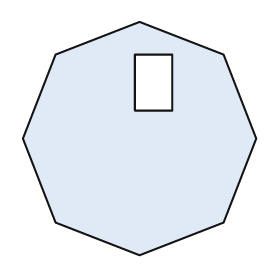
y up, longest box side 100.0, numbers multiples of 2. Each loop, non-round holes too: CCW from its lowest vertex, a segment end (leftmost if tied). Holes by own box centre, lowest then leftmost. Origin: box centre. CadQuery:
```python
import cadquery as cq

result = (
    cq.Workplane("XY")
    .moveTo(0.0, -50.0)
    .lineTo(36.0, -36.0)
    .lineTo(50.0, 0.0)
    .lineTo(36.0, 36.0)
    .lineTo(0.0, 50.0)
    .lineTo(-36.0, 36.0)
    .lineTo(-50.0, 0.0)
    .lineTo(-36.0, -36.0)
    .close()
    .moveTo(-2.0, 12.0)
    .lineTo(14.0, 12.0)
    .lineTo(14.0, 36.0)
    .lineTo(-2.0, 36.0)
    .close()
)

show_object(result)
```